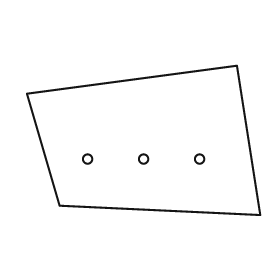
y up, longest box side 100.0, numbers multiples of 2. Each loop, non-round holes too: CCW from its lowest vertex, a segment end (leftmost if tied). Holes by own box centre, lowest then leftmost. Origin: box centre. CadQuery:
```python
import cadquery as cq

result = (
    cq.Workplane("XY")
    .moveTo(50.0, -32.0)
    .lineTo(40.0, 32.0)
    .lineTo(-50.0, 20.0)
    .lineTo(-36.0, -28.0)
    .close()
    .moveTo(-24.0, -8.0)
    .circle(2.0)
    .moveTo(0.0, -8.0)
    .circle(2.0)
    .moveTo(24.0, -8.0)
    .circle(2.0)
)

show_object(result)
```